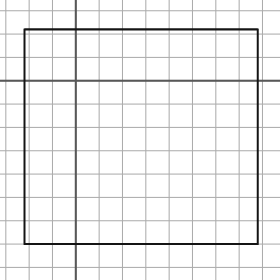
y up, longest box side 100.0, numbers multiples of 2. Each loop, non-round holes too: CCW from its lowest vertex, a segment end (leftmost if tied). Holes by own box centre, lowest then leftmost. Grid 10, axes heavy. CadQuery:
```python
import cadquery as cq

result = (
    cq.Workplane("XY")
    .moveTo(-22.0, -70.0)
    .lineTo(78.0, -70.0)
    .lineTo(78.0, 22.0)
    .lineTo(-22.0, 22.0)
    .close()
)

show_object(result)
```